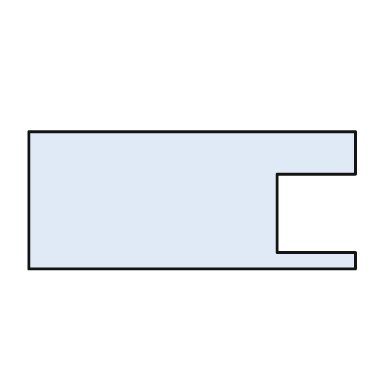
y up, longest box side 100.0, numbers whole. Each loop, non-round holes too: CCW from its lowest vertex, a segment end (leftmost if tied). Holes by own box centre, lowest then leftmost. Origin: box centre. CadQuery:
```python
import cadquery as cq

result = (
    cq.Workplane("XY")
    .moveTo(-50.0, -21.0)
    .lineTo(50.0, -21.0)
    .lineTo(50.0, -16.0)
    .lineTo(26.0, -16.0)
    .lineTo(26.0, 8.0)
    .lineTo(50.0, 8.0)
    .lineTo(50.0, 21.0)
    .lineTo(-50.0, 21.0)
    .close()
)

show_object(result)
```